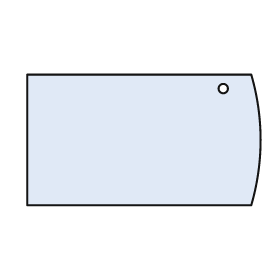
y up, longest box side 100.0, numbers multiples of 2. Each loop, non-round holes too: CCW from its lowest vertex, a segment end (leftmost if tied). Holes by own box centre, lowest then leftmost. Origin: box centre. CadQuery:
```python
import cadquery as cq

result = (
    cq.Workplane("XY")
    .moveTo(-50.0, -28.0)
    .lineTo(46.0, -28.0)
    .threePointArc((50.0, 0.0), (46.0, 28.0))
    .lineTo(-50.0, 28.0)
    .close()
    .moveTo(34.0, 22.0)
    .circle(2.0)
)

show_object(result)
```